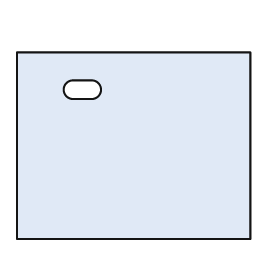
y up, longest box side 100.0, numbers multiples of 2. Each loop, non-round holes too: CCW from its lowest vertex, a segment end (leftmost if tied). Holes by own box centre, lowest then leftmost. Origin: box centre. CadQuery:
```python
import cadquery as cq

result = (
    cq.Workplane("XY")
    .moveTo(-50.0, -40.0)
    .lineTo(50.0, -40.0)
    .lineTo(50.0, 40.0)
    .lineTo(-50.0, 40.0)
    .close()
    .moveTo(-26.0, 20.0)
    .lineTo(-18.0, 20.0)
    .threePointArc((-14.0, 24.0), (-18.0, 28.0))
    .lineTo(-26.0, 28.0)
    .threePointArc((-30.0, 24.0), (-26.0, 20.0))
    .close()
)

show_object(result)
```